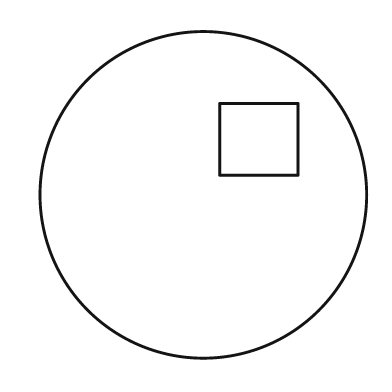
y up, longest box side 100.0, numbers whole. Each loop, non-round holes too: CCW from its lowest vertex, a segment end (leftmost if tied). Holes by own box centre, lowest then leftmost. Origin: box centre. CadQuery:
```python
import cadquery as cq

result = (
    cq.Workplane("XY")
    .moveTo(0.0, 0.0)
    .circle(50.0)
    .moveTo(5.0, 6.0)
    .lineTo(29.0, 6.0)
    .lineTo(29.0, 28.0)
    .lineTo(5.0, 28.0)
    .close()
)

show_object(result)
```